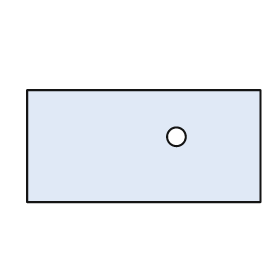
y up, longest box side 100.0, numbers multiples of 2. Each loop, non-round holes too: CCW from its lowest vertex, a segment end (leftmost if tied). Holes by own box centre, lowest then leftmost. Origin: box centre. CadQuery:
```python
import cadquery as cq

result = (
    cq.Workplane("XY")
    .moveTo(-50.0, -24.0)
    .lineTo(50.0, -24.0)
    .lineTo(50.0, 24.0)
    .lineTo(-50.0, 24.0)
    .close()
    .moveTo(14.0, 4.0)
    .circle(4.0)
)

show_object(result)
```